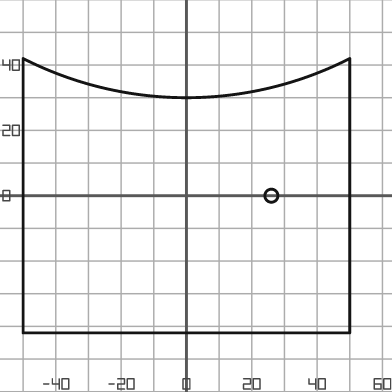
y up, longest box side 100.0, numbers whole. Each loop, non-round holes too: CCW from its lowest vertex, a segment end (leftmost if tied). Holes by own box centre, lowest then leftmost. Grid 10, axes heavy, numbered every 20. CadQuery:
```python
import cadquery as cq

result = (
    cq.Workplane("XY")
    .moveTo(-50.0, -42.0)
    .lineTo(50.0, -42.0)
    .lineTo(50.0, 42.0)
    .threePointArc((0.0, 30.0), (-50.0, 42.0))
    .close()
    .moveTo(26.0, 0.0)
    .circle(2.0)
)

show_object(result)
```